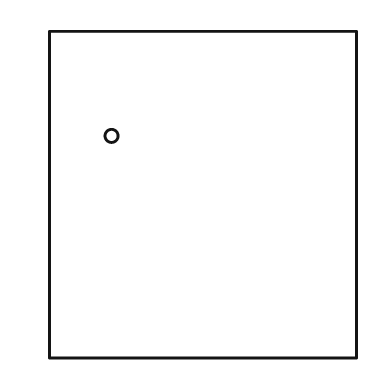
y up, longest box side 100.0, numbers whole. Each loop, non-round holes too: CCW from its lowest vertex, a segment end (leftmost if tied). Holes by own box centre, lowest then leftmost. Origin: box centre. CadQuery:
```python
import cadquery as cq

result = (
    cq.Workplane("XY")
    .moveTo(-47.0, -50.0)
    .lineTo(47.0, -50.0)
    .lineTo(47.0, 50.0)
    .lineTo(-47.0, 50.0)
    .close()
    .moveTo(-28.0, 18.0)
    .circle(2.0)
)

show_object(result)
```